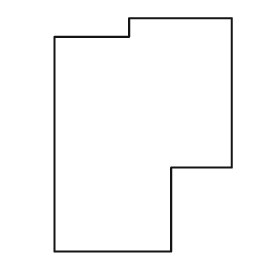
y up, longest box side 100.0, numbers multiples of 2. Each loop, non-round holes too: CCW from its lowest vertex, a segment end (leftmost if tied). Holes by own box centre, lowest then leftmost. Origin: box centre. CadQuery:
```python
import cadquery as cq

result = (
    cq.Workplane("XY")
    .moveTo(-38.0, -50.0)
    .lineTo(12.0, -50.0)
    .lineTo(12.0, -14.0)
    .lineTo(38.0, -14.0)
    .lineTo(38.0, 50.0)
    .lineTo(-6.0, 50.0)
    .lineTo(-6.0, 42.0)
    .lineTo(-38.0, 42.0)
    .close()
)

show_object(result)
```